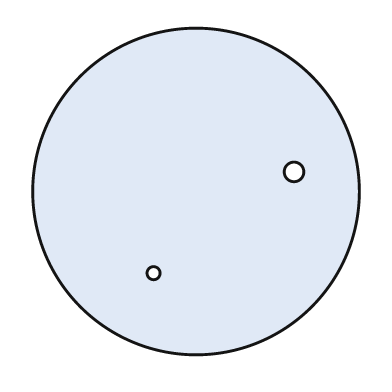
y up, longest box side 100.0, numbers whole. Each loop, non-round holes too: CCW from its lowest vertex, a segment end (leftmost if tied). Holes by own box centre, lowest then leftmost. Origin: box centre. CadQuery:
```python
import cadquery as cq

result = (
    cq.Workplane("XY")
    .moveTo(0.0, 0.0)
    .circle(50.0)
    .moveTo(-13.0, -25.0)
    .circle(2.0)
    .moveTo(30.0, 6.0)
    .circle(3.0)
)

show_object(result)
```